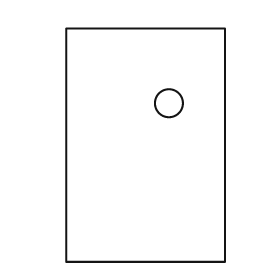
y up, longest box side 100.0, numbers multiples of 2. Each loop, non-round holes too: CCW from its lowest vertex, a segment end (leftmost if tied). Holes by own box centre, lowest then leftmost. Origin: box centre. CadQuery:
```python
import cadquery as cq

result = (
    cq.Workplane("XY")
    .moveTo(-34.0, -50.0)
    .lineTo(34.0, -50.0)
    .lineTo(34.0, 50.0)
    .lineTo(-34.0, 50.0)
    .close()
    .moveTo(10.0, 18.0)
    .circle(6.0)
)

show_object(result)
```